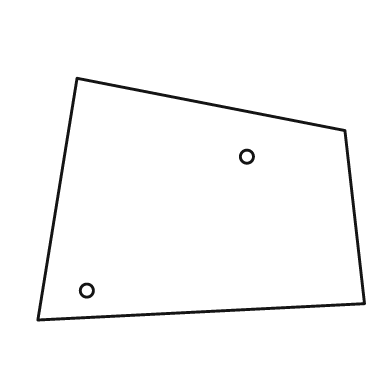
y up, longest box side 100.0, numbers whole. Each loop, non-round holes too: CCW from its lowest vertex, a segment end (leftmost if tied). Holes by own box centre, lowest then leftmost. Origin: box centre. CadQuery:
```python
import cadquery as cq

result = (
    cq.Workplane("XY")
    .moveTo(-50.0, -37.0)
    .lineTo(50.0, -32.0)
    .lineTo(44.0, 21.0)
    .lineTo(-38.0, 37.0)
    .close()
    .moveTo(-35.0, -28.0)
    .circle(2.0)
    .moveTo(14.0, 13.0)
    .circle(2.0)
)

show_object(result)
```